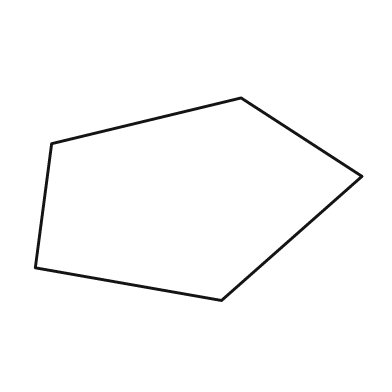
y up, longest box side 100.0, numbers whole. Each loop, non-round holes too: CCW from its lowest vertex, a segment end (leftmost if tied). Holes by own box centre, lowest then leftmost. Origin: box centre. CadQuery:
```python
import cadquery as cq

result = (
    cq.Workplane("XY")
    .moveTo(7.0, -31.0)
    .lineTo(50.0, 7.0)
    .lineTo(13.0, 31.0)
    .lineTo(-45.0, 17.0)
    .lineTo(-50.0, -21.0)
    .close()
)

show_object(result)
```